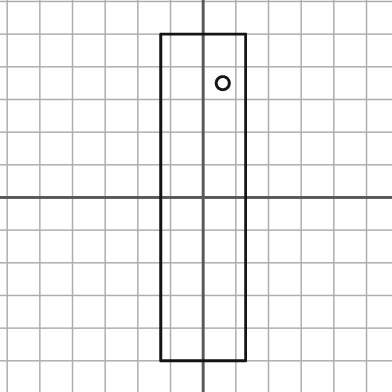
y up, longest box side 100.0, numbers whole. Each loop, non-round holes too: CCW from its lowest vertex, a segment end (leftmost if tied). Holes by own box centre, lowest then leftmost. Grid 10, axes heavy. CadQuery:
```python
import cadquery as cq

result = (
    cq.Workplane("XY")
    .moveTo(-13.0, -50.0)
    .lineTo(13.0, -50.0)
    .lineTo(13.0, 50.0)
    .lineTo(-13.0, 50.0)
    .close()
    .moveTo(6.0, 35.0)
    .circle(2.0)
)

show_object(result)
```